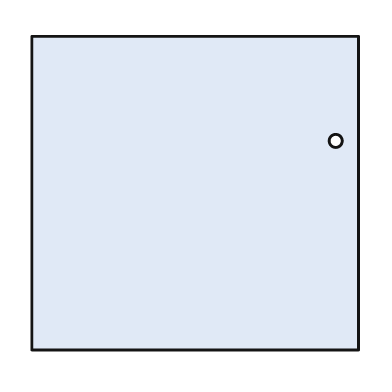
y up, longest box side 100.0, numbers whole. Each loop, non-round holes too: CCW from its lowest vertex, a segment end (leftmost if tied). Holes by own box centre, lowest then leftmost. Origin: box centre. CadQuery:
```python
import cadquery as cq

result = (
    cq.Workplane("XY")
    .moveTo(-50.0, -48.0)
    .lineTo(50.0, -48.0)
    .lineTo(50.0, 48.0)
    .lineTo(-50.0, 48.0)
    .close()
    .moveTo(43.0, 16.0)
    .circle(2.0)
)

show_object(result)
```